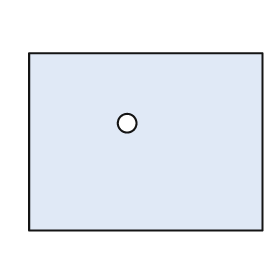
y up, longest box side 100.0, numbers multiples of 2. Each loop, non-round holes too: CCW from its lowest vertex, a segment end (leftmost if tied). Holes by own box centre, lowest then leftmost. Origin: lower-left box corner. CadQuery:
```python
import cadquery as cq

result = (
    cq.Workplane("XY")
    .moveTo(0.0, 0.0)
    .lineTo(100.0, 0.0)
    .lineTo(100.0, 76.0)
    .lineTo(0.0, 76.0)
    .close()
    .moveTo(42.0, 46.0)
    .circle(4.0)
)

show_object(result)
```